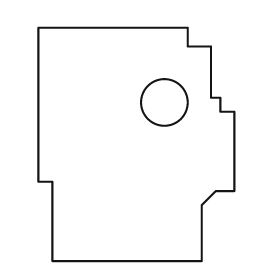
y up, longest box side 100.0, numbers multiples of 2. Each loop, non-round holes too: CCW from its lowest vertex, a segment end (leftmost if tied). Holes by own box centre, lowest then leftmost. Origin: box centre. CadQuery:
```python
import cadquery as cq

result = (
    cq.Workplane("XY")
    .moveTo(-36.0, -50.0)
    .lineTo(28.0, -50.0)
    .lineTo(28.0, -26.0)
    .lineTo(34.0, -20.0)
    .lineTo(42.0, -20.0)
    .lineTo(42.0, 14.0)
    .lineTo(36.0, 14.0)
    .lineTo(36.0, 20.0)
    .lineTo(32.0, 20.0)
    .lineTo(32.0, 42.0)
    .lineTo(22.0, 42.0)
    .lineTo(22.0, 50.0)
    .lineTo(-42.0, 50.0)
    .lineTo(-42.0, -16.0)
    .lineTo(-36.0, -16.0)
    .close()
    .moveTo(12.0, 18.0)
    .circle(10.0)
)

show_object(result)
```